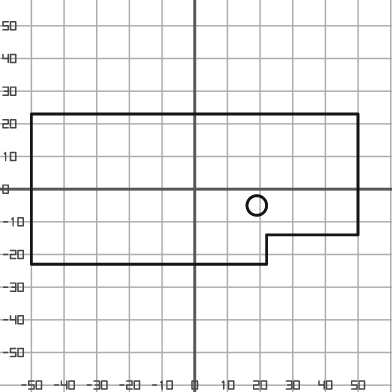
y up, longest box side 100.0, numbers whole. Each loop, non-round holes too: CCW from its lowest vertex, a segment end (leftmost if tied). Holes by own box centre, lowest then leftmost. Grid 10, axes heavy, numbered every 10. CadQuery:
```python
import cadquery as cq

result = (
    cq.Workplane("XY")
    .moveTo(-50.0, -23.0)
    .lineTo(22.0, -23.0)
    .lineTo(22.0, -14.0)
    .lineTo(50.0, -14.0)
    .lineTo(50.0, 23.0)
    .lineTo(-50.0, 23.0)
    .close()
    .moveTo(19.0, -5.0)
    .circle(3.0)
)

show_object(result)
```